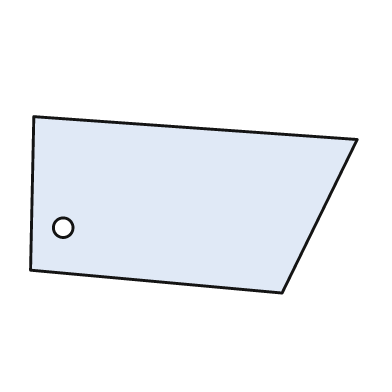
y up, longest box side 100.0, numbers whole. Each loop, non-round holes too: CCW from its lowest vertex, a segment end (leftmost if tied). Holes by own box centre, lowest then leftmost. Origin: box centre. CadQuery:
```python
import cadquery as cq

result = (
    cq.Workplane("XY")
    .moveTo(27.0, -27.0)
    .lineTo(50.0, 20.0)
    .lineTo(-49.0, 27.0)
    .lineTo(-50.0, -20.0)
    .close()
    .moveTo(-40.0, -7.0)
    .circle(3.0)
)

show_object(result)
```